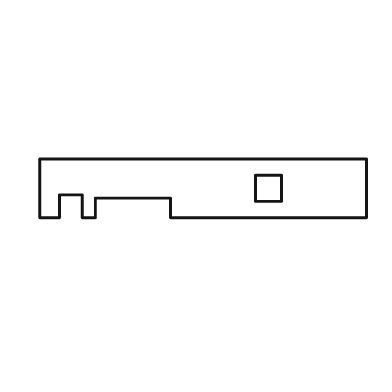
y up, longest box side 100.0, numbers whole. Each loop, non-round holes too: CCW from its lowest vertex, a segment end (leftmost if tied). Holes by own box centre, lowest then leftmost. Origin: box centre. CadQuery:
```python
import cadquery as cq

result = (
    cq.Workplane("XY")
    .moveTo(-50.0, -9.0)
    .lineTo(-44.0, -9.0)
    .lineTo(-44.0, -2.0)
    .lineTo(-37.0, -2.0)
    .lineTo(-37.0, -9.0)
    .lineTo(-33.0, -9.0)
    .lineTo(-33.0, -3.0)
    .lineTo(-10.0, -3.0)
    .lineTo(-10.0, -9.0)
    .lineTo(50.0, -9.0)
    .lineTo(50.0, 9.0)
    .lineTo(-50.0, 9.0)
    .close()
    .moveTo(16.0, -4.0)
    .lineTo(24.0, -4.0)
    .lineTo(24.0, 4.0)
    .lineTo(16.0, 4.0)
    .close()
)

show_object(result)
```